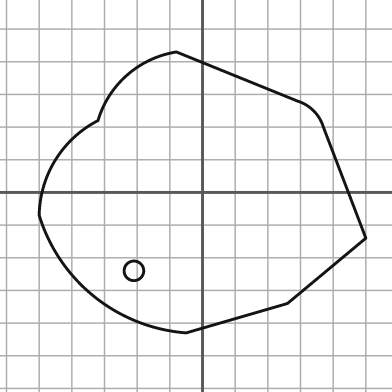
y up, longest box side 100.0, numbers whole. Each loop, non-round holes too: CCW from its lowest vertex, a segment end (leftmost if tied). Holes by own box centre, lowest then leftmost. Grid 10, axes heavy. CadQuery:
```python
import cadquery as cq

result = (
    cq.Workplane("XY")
    .moveTo(-5.0, -43.0)
    .lineTo(26.0, -34.0)
    .lineTo(50.0, -14.0)
    .lineTo(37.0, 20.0)
    .threePointArc((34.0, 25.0), (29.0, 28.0))
    .lineTo(-8.0, 43.0)
    .threePointArc((-23.0, 36.0), (-32.0, 22.0))
    .threePointArc((-45.0, 10.0), (-50.0, -7.0))
    .threePointArc((-33.0, -32.0), (-5.0, -43.0))
    .close()
    .moveTo(-21.0, -24.0)
    .circle(3.0)
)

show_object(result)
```